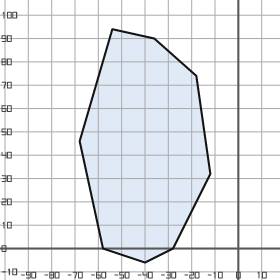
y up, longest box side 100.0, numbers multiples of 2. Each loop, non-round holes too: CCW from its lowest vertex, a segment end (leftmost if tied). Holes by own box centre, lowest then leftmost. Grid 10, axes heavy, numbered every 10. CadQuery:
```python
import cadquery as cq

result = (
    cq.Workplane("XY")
    .moveTo(-40.0, -6.0)
    .lineTo(-28.0, 0.0)
    .lineTo(-12.0, 32.0)
    .lineTo(-18.0, 74.0)
    .lineTo(-36.0, 90.0)
    .lineTo(-54.0, 94.0)
    .lineTo(-68.0, 46.0)
    .lineTo(-58.0, 0.0)
    .close()
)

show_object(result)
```